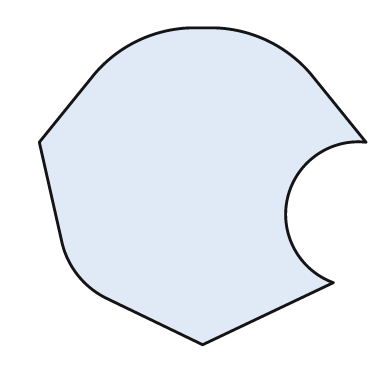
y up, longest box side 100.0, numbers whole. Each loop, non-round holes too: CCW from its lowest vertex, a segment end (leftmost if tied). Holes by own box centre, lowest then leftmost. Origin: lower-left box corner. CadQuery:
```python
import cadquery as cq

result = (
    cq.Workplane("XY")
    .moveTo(50.0, 0.0)
    .lineTo(90.0, 19.0)
    .threePointArc((76.0, 45.0), (100.0, 62.0))
    .lineTo(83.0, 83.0)
    .threePointArc((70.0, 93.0), (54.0, 97.0))
    .lineTo(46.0, 97.0)
    .threePointArc((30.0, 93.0), (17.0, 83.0))
    .lineTo(0.0, 62.0)
    .lineTo(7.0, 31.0)
    .threePointArc((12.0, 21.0), (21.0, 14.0))
    .close()
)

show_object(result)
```